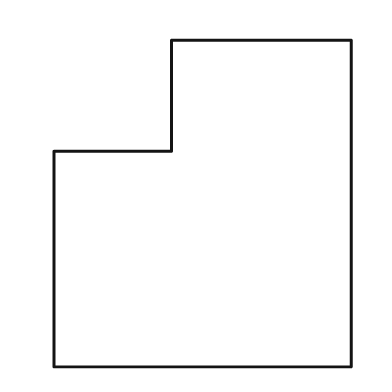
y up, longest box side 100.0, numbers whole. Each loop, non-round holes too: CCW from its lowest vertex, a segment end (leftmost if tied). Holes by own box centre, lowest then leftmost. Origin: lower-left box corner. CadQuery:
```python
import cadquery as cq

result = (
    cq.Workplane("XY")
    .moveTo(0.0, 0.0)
    .lineTo(91.0, 0.0)
    .lineTo(91.0, 100.0)
    .lineTo(36.0, 100.0)
    .lineTo(36.0, 66.0)
    .lineTo(0.0, 66.0)
    .close()
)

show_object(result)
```